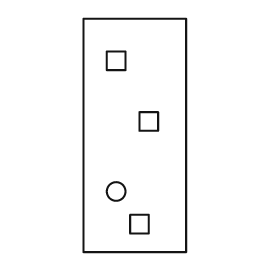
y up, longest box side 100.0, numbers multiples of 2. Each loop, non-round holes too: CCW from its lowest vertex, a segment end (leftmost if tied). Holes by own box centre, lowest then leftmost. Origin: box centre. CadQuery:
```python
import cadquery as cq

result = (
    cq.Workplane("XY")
    .moveTo(-22.0, -50.0)
    .lineTo(22.0, -50.0)
    .lineTo(22.0, 50.0)
    .lineTo(-22.0, 50.0)
    .close()
    .moveTo(-2.0, -42.0)
    .lineTo(6.0, -42.0)
    .lineTo(6.0, -34.0)
    .lineTo(-2.0, -34.0)
    .close()
    .moveTo(-8.0, -24.0)
    .circle(4.0)
    .moveTo(2.0, 2.0)
    .lineTo(10.0, 2.0)
    .lineTo(10.0, 10.0)
    .lineTo(2.0, 10.0)
    .close()
    .moveTo(-12.0, 28.0)
    .lineTo(-4.0, 28.0)
    .lineTo(-4.0, 36.0)
    .lineTo(-12.0, 36.0)
    .close()
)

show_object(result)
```